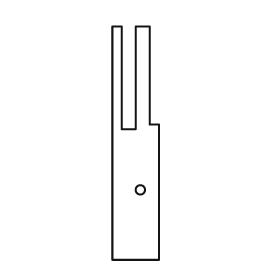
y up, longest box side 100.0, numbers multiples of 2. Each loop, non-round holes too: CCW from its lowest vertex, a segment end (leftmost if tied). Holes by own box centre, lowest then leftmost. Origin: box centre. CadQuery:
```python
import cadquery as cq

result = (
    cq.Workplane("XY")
    .moveTo(-10.0, -50.0)
    .lineTo(10.0, -50.0)
    .lineTo(10.0, 8.0)
    .lineTo(6.0, 8.0)
    .lineTo(6.0, 50.0)
    .lineTo(0.0, 50.0)
    .lineTo(0.0, 6.0)
    .lineTo(-6.0, 6.0)
    .lineTo(-6.0, 50.0)
    .lineTo(-10.0, 50.0)
    .close()
    .moveTo(2.0, -20.0)
    .circle(2.0)
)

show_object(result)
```